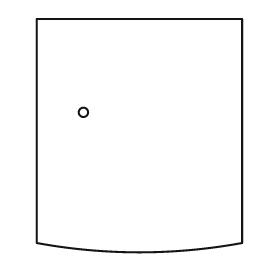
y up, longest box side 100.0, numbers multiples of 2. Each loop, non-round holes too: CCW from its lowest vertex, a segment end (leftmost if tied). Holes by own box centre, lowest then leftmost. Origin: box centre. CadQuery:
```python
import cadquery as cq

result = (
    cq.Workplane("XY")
    .moveTo(-44.0, -46.0)
    .threePointArc((0.0, -50.0), (44.0, -46.0))
    .lineTo(44.0, 50.0)
    .lineTo(-44.0, 50.0)
    .close()
    .moveTo(-24.0, 10.0)
    .circle(2.0)
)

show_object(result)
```